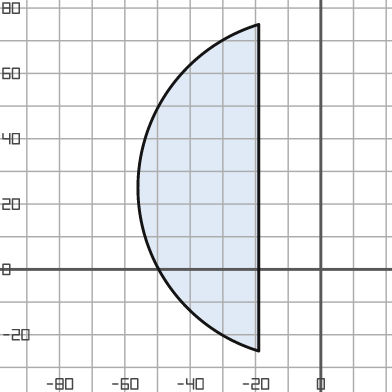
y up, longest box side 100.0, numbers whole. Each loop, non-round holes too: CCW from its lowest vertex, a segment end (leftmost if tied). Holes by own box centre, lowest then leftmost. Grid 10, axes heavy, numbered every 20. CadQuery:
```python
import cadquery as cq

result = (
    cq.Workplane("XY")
    .moveTo(-19.0, -25.0)
    .lineTo(-19.0, 75.0)
    .threePointArc((-56.0, 25.0), (-19.0, -25.0))
    .close()
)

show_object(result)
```